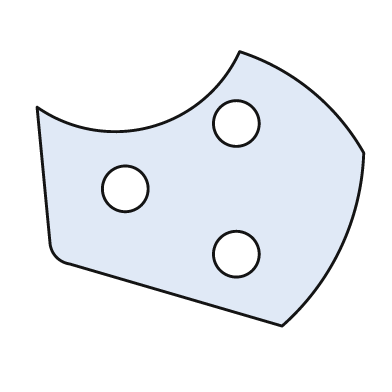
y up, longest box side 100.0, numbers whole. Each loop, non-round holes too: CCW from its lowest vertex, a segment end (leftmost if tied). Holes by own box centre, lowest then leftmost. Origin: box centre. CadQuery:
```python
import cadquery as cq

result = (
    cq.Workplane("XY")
    .moveTo(25.0, -42.0)
    .threePointArc((43.0, -18.0), (50.0, 11.0))
    .threePointArc((34.0, 30.0), (12.0, 42.0))
    .threePointArc((-15.0, 19.0), (-50.0, 25.0))
    .lineTo(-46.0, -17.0)
    .threePointArc((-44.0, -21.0), (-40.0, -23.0))
    .close()
    .moveTo(11.0, -20.0)
    .circle(7.0)
    .moveTo(-23.0, 0.0)
    .circle(7.0)
    .moveTo(11.0, 20.0)
    .circle(7.0)
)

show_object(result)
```